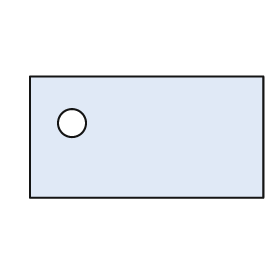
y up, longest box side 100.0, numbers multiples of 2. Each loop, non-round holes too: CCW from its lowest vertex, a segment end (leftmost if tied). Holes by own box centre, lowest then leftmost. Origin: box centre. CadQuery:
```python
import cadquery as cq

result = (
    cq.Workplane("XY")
    .moveTo(-50.0, -26.0)
    .lineTo(50.0, -26.0)
    .lineTo(50.0, 26.0)
    .lineTo(-50.0, 26.0)
    .close()
    .moveTo(-32.0, 6.0)
    .circle(6.0)
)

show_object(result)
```